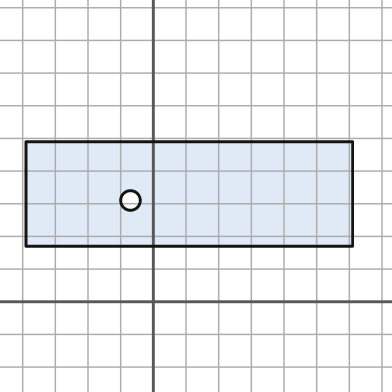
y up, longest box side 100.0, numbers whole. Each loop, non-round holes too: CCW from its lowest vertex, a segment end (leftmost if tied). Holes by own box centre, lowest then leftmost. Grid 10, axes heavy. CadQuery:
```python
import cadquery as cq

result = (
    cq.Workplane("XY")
    .moveTo(-39.0, 17.0)
    .lineTo(61.0, 17.0)
    .lineTo(61.0, 49.0)
    .lineTo(-39.0, 49.0)
    .close()
    .moveTo(-7.0, 31.0)
    .circle(3.0)
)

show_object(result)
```